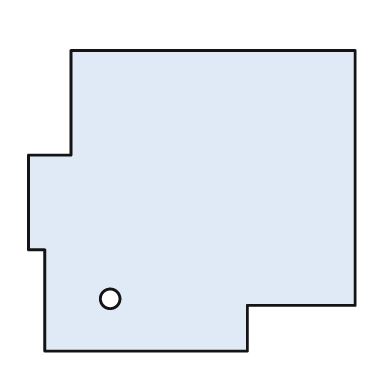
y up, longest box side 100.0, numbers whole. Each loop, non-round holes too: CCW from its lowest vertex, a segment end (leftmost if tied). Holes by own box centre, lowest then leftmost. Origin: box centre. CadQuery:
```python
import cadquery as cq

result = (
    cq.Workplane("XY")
    .moveTo(-45.0, -46.0)
    .lineTo(17.0, -46.0)
    .lineTo(17.0, -32.0)
    .lineTo(50.0, -32.0)
    .lineTo(50.0, 46.0)
    .lineTo(-37.0, 46.0)
    .lineTo(-37.0, 14.0)
    .lineTo(-50.0, 14.0)
    .lineTo(-50.0, -15.0)
    .lineTo(-45.0, -15.0)
    .close()
    .moveTo(-25.0, -30.0)
    .circle(3.0)
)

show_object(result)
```